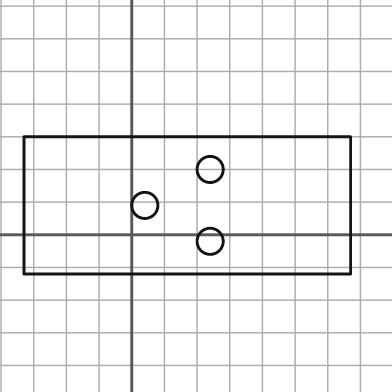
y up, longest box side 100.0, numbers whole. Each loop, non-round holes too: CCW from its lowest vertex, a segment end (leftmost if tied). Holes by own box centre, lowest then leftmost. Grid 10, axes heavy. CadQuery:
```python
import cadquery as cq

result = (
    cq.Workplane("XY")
    .moveTo(-33.0, -12.0)
    .lineTo(67.0, -12.0)
    .lineTo(67.0, 30.0)
    .lineTo(-33.0, 30.0)
    .close()
    .moveTo(24.0, -2.0)
    .circle(4.0)
    .moveTo(4.0, 9.0)
    .circle(4.0)
    .moveTo(24.0, 20.0)
    .circle(4.0)
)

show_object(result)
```